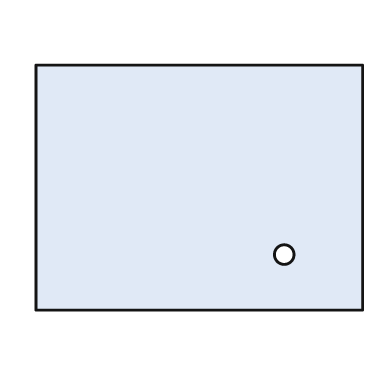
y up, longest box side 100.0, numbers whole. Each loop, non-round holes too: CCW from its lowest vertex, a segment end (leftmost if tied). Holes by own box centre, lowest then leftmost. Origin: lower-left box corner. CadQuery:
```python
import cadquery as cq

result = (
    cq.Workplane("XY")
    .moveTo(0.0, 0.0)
    .lineTo(100.0, 0.0)
    .lineTo(100.0, 75.0)
    .lineTo(0.0, 75.0)
    .close()
    .moveTo(76.0, 17.0)
    .circle(3.0)
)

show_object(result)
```